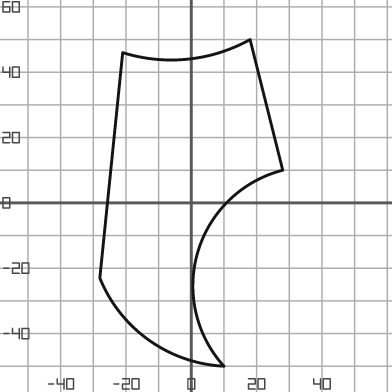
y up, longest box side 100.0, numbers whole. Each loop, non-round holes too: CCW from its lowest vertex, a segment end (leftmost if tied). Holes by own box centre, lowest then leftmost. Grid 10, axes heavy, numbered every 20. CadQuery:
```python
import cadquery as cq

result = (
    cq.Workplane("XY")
    .moveTo(10.0, -50.0)
    .threePointArc((2.0, -15.0), (28.0, 10.0))
    .lineTo(18.0, 50.0)
    .threePointArc((-1.0, 44.0), (-21.0, 46.0))
    .lineTo(-28.0, -23.0)
    .threePointArc((-13.0, -42.0), (10.0, -50.0))
    .close()
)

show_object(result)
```